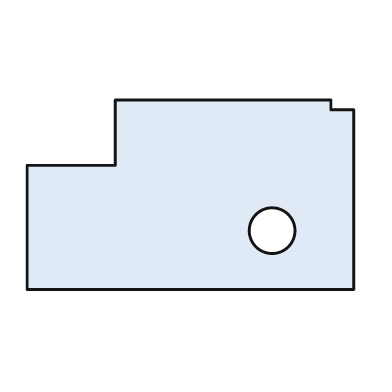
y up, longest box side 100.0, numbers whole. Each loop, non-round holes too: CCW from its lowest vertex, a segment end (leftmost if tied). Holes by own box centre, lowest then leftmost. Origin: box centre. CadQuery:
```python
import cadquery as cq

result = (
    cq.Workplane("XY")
    .moveTo(-50.0, -29.0)
    .lineTo(50.0, -29.0)
    .lineTo(50.0, 26.0)
    .lineTo(43.0, 26.0)
    .lineTo(43.0, 29.0)
    .lineTo(-23.0, 29.0)
    .lineTo(-23.0, 9.0)
    .lineTo(-50.0, 9.0)
    .close()
    .moveTo(25.0, -11.0)
    .circle(7.0)
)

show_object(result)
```